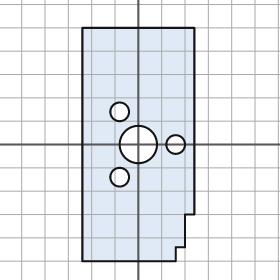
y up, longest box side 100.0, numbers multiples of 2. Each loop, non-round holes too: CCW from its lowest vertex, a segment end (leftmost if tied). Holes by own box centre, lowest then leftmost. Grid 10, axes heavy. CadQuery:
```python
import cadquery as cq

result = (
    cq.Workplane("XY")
    .moveTo(-24.0, -50.0)
    .lineTo(16.0, -50.0)
    .lineTo(16.0, -44.0)
    .lineTo(20.0, -44.0)
    .lineTo(20.0, -30.0)
    .lineTo(24.0, -30.0)
    .lineTo(24.0, 50.0)
    .lineTo(-24.0, 50.0)
    .close()
    .moveTo(-8.0, -14.0)
    .circle(4.0)
    .moveTo(0.0, 0.0)
    .circle(8.0)
    .moveTo(16.0, 0.0)
    .circle(4.0)
    .moveTo(-8.0, 14.0)
    .circle(4.0)
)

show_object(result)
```